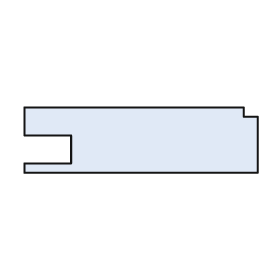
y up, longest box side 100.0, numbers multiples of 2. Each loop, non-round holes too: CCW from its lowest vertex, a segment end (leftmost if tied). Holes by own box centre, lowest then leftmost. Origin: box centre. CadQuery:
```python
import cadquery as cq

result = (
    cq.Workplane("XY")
    .moveTo(-50.0, -14.0)
    .lineTo(50.0, -14.0)
    .lineTo(50.0, 10.0)
    .lineTo(44.0, 10.0)
    .lineTo(44.0, 14.0)
    .lineTo(-50.0, 14.0)
    .lineTo(-50.0, 2.0)
    .lineTo(-30.0, 2.0)
    .lineTo(-30.0, -10.0)
    .lineTo(-50.0, -10.0)
    .close()
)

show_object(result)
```